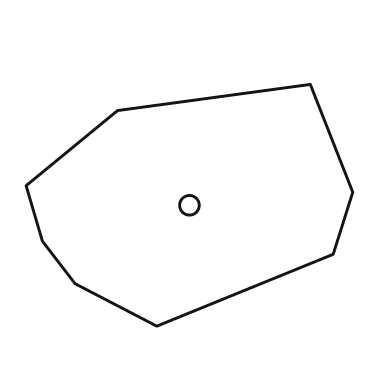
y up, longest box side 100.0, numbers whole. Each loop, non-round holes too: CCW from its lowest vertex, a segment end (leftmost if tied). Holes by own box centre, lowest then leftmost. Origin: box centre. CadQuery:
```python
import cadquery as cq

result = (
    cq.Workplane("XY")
    .moveTo(-10.0, -37.0)
    .lineTo(44.0, -15.0)
    .lineTo(50.0, 4.0)
    .lineTo(37.0, 37.0)
    .lineTo(-22.0, 29.0)
    .lineTo(-50.0, 6.0)
    .lineTo(-45.0, -11.0)
    .lineTo(-35.0, -24.0)
    .close()
    .moveTo(0.0, 0.0)
    .circle(3.0)
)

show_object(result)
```